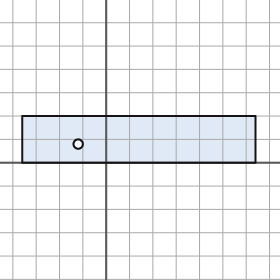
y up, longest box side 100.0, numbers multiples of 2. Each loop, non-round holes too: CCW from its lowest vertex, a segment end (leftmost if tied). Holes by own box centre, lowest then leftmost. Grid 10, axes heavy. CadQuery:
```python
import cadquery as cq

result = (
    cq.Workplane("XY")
    .moveTo(-36.0, 0.0)
    .lineTo(64.0, 0.0)
    .lineTo(64.0, 20.0)
    .lineTo(-36.0, 20.0)
    .close()
    .moveTo(-12.0, 8.0)
    .circle(2.0)
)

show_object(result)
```